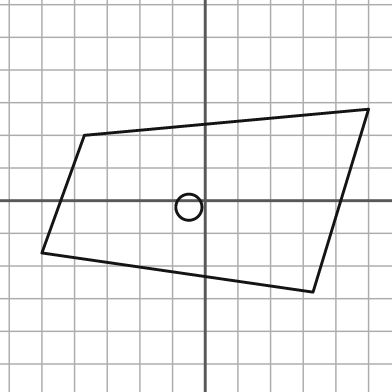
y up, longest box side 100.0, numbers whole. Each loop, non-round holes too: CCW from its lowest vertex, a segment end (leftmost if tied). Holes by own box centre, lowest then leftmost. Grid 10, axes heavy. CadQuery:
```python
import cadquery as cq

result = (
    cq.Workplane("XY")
    .moveTo(33.0, -28.0)
    .lineTo(50.0, 28.0)
    .lineTo(-37.0, 20.0)
    .lineTo(-50.0, -16.0)
    .close()
    .moveTo(-5.0, -2.0)
    .circle(4.0)
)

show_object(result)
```